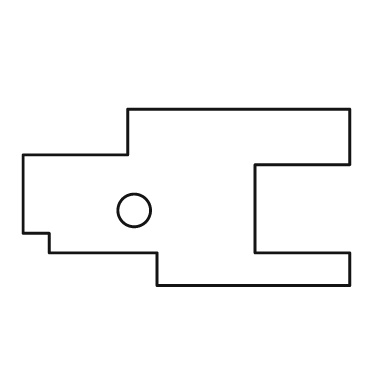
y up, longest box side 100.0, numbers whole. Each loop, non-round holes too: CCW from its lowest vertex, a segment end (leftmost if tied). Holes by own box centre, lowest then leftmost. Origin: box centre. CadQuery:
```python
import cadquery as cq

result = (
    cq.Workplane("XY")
    .moveTo(-9.0, -27.0)
    .lineTo(50.0, -27.0)
    .lineTo(50.0, -17.0)
    .lineTo(21.0, -17.0)
    .lineTo(21.0, 10.0)
    .lineTo(50.0, 10.0)
    .lineTo(50.0, 27.0)
    .lineTo(-18.0, 27.0)
    .lineTo(-18.0, 13.0)
    .lineTo(-50.0, 13.0)
    .lineTo(-50.0, -11.0)
    .lineTo(-42.0, -11.0)
    .lineTo(-42.0, -17.0)
    .lineTo(-9.0, -17.0)
    .close()
    .moveTo(-16.0, -4.0)
    .circle(5.0)
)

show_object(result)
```